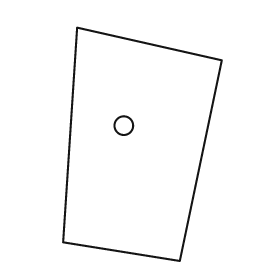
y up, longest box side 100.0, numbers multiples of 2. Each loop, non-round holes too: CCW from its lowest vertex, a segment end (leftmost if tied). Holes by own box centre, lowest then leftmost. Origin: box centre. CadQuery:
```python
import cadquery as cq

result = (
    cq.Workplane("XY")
    .moveTo(16.0, -50.0)
    .lineTo(34.0, 36.0)
    .lineTo(-28.0, 50.0)
    .lineTo(-34.0, -42.0)
    .close()
    .moveTo(-8.0, 8.0)
    .circle(4.0)
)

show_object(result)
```